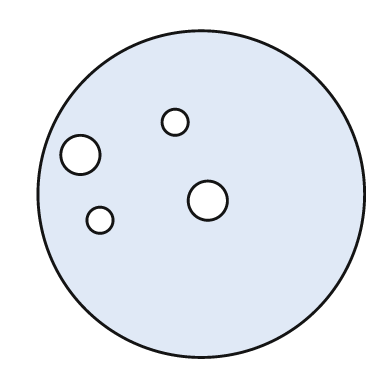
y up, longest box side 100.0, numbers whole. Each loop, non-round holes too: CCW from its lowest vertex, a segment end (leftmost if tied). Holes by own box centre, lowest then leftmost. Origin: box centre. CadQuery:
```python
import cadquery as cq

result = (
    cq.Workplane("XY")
    .moveTo(0.0, 0.0)
    .circle(50.0)
    .moveTo(-31.0, -8.0)
    .circle(4.0)
    .moveTo(2.0, -2.0)
    .circle(6.0)
    .moveTo(-37.0, 12.0)
    .circle(6.0)
    .moveTo(-8.0, 22.0)
    .circle(4.0)
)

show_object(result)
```